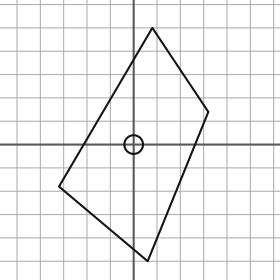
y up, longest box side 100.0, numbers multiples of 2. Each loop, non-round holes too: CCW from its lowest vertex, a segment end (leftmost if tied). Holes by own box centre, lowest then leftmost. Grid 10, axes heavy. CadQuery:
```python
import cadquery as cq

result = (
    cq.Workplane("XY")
    .moveTo(6.0, -50.0)
    .lineTo(32.0, 14.0)
    .lineTo(8.0, 50.0)
    .lineTo(-32.0, -18.0)
    .close()
    .moveTo(0.0, 0.0)
    .circle(4.0)
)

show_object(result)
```